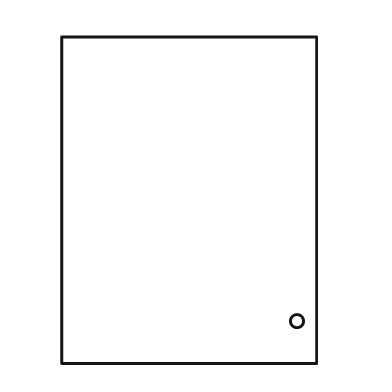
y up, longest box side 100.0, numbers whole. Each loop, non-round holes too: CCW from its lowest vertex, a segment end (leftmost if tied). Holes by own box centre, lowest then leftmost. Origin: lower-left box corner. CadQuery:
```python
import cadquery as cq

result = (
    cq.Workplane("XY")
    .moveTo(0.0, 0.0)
    .lineTo(78.0, 0.0)
    .lineTo(78.0, 100.0)
    .lineTo(0.0, 100.0)
    .close()
    .moveTo(72.0, 13.0)
    .circle(2.0)
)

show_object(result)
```